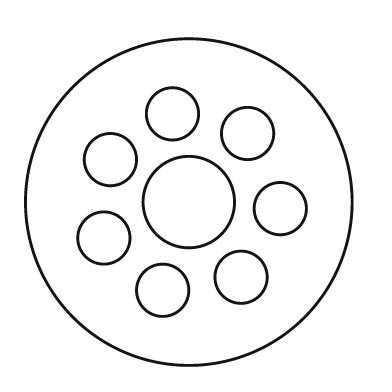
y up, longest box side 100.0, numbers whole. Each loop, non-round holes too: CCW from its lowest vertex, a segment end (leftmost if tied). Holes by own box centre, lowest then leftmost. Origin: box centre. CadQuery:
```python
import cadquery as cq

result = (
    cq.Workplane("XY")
    .moveTo(0.0, 0.0)
    .circle(50.0)
    .moveTo(-8.0, -27.0)
    .circle(8.0)
    .moveTo(16.0, -23.0)
    .circle(8.0)
    .moveTo(-26.0, -11.0)
    .circle(8.0)
    .moveTo(28.0, -2.0)
    .circle(8.0)
    .moveTo(0.0, 0.0)
    .circle(14.0)
    .moveTo(-24.0, 13.0)
    .circle(8.0)
    .moveTo(18.0, 21.0)
    .circle(8.0)
    .moveTo(-5.0, 27.0)
    .circle(8.0)
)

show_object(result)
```